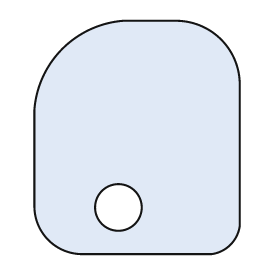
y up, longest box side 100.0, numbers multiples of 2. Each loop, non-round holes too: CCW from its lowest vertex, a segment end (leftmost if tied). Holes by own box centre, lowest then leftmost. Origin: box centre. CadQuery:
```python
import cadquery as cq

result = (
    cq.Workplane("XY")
    .moveTo(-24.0, -50.0)
    .lineTo(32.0, -50.0)
    .threePointArc((40.0, -46.0), (44.0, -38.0))
    .lineTo(44.0, 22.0)
    .threePointArc((36.0, 42.0), (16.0, 50.0))
    .lineTo(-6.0, 50.0)
    .threePointArc((-32.0, 38.0), (-44.0, 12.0))
    .lineTo(-44.0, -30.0)
    .threePointArc((-38.0, -44.0), (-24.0, -50.0))
    .close()
    .moveTo(-8.0, -30.0)
    .circle(10.0)
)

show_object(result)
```